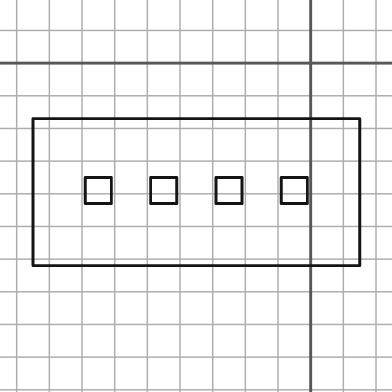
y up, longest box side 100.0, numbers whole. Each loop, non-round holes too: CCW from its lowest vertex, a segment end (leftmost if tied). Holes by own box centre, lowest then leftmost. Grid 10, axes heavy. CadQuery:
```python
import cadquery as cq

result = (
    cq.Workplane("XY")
    .moveTo(-85.0, -62.0)
    .lineTo(15.0, -62.0)
    .lineTo(15.0, -17.0)
    .lineTo(-85.0, -17.0)
    .close()
    .moveTo(-69.0, -43.0)
    .lineTo(-61.0, -43.0)
    .lineTo(-61.0, -35.0)
    .lineTo(-69.0, -35.0)
    .close()
    .moveTo(-49.0, -43.0)
    .lineTo(-41.0, -43.0)
    .lineTo(-41.0, -35.0)
    .lineTo(-49.0, -35.0)
    .close()
    .moveTo(-29.0, -43.0)
    .lineTo(-21.0, -43.0)
    .lineTo(-21.0, -35.0)
    .lineTo(-29.0, -35.0)
    .close()
    .moveTo(-9.0, -43.0)
    .lineTo(-1.0, -43.0)
    .lineTo(-1.0, -35.0)
    .lineTo(-9.0, -35.0)
    .close()
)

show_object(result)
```